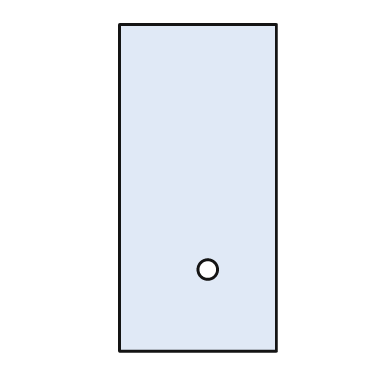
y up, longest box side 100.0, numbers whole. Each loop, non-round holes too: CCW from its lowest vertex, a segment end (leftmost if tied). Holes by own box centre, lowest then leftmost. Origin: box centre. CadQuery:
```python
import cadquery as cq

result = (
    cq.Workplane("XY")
    .moveTo(-24.0, -50.0)
    .lineTo(24.0, -50.0)
    .lineTo(24.0, 50.0)
    .lineTo(-24.0, 50.0)
    .close()
    .moveTo(3.0, -25.0)
    .circle(3.0)
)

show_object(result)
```